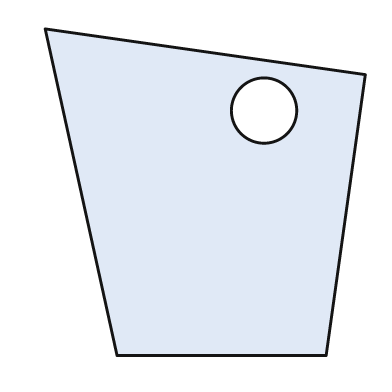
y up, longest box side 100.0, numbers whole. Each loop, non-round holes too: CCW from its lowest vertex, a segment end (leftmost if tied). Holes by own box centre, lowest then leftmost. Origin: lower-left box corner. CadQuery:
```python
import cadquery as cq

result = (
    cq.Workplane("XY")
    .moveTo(22.0, 0.0)
    .lineTo(86.0, 0.0)
    .lineTo(98.0, 86.0)
    .lineTo(0.0, 100.0)
    .close()
    .moveTo(67.0, 75.0)
    .circle(10.0)
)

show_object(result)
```